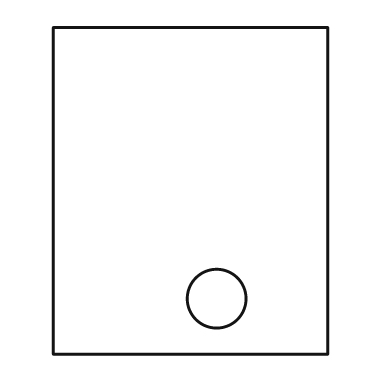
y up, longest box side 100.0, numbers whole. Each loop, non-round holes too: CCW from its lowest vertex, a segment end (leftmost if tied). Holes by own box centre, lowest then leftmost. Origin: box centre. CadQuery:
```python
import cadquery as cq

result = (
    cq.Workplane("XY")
    .moveTo(-42.0, -50.0)
    .lineTo(42.0, -50.0)
    .lineTo(42.0, 50.0)
    .lineTo(-42.0, 50.0)
    .close()
    .moveTo(8.0, -33.0)
    .circle(9.0)
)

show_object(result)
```